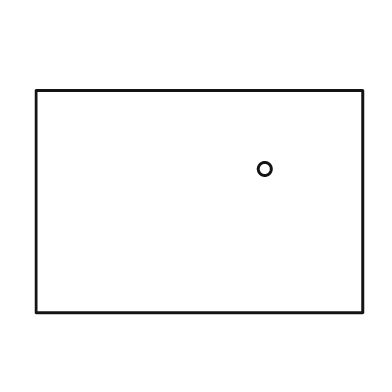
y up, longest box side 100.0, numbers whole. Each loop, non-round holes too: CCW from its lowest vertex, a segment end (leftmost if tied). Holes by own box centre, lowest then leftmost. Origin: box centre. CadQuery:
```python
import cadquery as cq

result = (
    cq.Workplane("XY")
    .moveTo(-50.0, -34.0)
    .lineTo(50.0, -34.0)
    .lineTo(50.0, 34.0)
    .lineTo(-50.0, 34.0)
    .close()
    .moveTo(20.0, 10.0)
    .circle(2.0)
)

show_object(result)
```